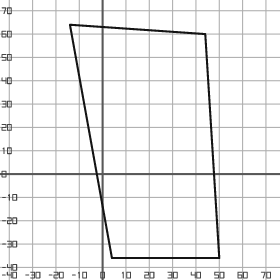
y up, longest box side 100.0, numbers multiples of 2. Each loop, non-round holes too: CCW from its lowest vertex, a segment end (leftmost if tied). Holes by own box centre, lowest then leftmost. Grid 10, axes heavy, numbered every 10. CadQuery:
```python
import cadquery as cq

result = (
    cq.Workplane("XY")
    .moveTo(4.0, -36.0)
    .lineTo(50.0, -36.0)
    .lineTo(44.0, 60.0)
    .lineTo(-14.0, 64.0)
    .close()
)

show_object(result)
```